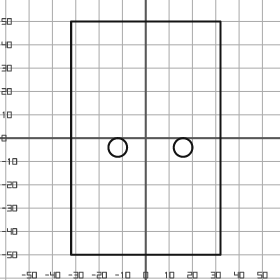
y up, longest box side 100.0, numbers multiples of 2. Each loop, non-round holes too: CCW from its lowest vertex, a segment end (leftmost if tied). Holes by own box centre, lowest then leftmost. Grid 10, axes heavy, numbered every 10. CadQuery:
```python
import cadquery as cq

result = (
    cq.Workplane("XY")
    .moveTo(-32.0, -50.0)
    .lineTo(32.0, -50.0)
    .lineTo(32.0, 50.0)
    .lineTo(-32.0, 50.0)
    .close()
    .moveTo(-12.0, -4.0)
    .circle(4.0)
    .moveTo(16.0, -4.0)
    .circle(4.0)
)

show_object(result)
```